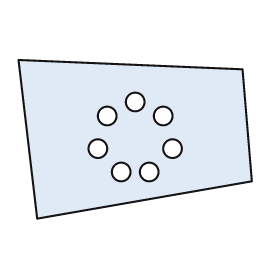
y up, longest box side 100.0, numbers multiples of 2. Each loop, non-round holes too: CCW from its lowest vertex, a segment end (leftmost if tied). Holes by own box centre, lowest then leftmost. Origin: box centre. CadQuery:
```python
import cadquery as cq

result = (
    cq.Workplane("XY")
    .moveTo(-42.0, -34.0)
    .lineTo(50.0, -18.0)
    .lineTo(46.0, 30.0)
    .lineTo(-50.0, 34.0)
    .close()
    .moveTo(-6.0, -14.0)
    .circle(4.0)
    .moveTo(6.0, -14.0)
    .circle(4.0)
    .moveTo(-16.0, -4.0)
    .circle(4.0)
    .moveTo(16.0, -4.0)
    .circle(4.0)
    .moveTo(-12.0, 10.0)
    .circle(4.0)
    .moveTo(12.0, 10.0)
    .circle(4.0)
    .moveTo(0.0, 16.0)
    .circle(4.0)
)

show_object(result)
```